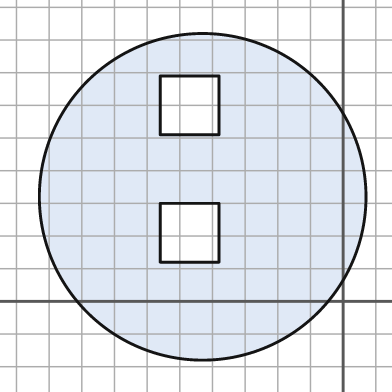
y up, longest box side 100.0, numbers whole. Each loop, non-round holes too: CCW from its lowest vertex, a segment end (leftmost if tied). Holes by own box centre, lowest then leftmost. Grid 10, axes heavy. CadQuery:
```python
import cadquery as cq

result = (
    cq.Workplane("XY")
    .moveTo(-43.0, 32.0)
    .circle(50.0)
    .moveTo(-56.0, 12.0)
    .lineTo(-38.0, 12.0)
    .lineTo(-38.0, 30.0)
    .lineTo(-56.0, 30.0)
    .close()
    .moveTo(-56.0, 51.0)
    .lineTo(-38.0, 51.0)
    .lineTo(-38.0, 69.0)
    .lineTo(-56.0, 69.0)
    .close()
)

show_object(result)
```